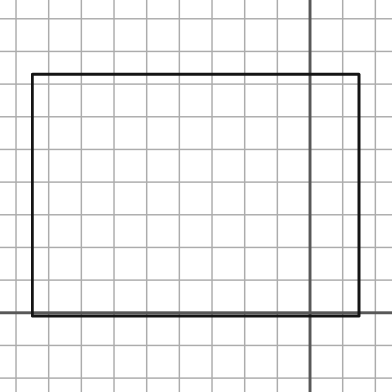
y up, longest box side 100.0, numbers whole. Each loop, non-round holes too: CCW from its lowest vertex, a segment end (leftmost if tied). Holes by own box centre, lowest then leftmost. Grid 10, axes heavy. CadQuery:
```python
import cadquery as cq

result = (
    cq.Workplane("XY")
    .moveTo(-85.0, -1.0)
    .lineTo(15.0, -1.0)
    .lineTo(15.0, 73.0)
    .lineTo(-85.0, 73.0)
    .close()
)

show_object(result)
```